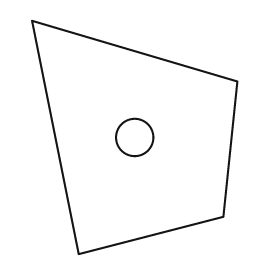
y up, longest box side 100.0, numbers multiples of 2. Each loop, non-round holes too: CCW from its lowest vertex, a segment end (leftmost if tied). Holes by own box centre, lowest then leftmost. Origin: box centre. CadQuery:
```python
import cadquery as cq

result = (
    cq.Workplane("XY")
    .moveTo(-24.0, -50.0)
    .lineTo(38.0, -34.0)
    .lineTo(44.0, 24.0)
    .lineTo(-44.0, 50.0)
    .close()
    .moveTo(0.0, 0.0)
    .circle(8.0)
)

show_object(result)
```